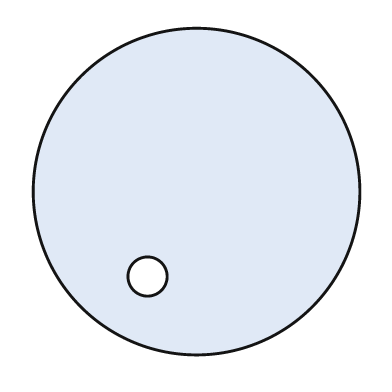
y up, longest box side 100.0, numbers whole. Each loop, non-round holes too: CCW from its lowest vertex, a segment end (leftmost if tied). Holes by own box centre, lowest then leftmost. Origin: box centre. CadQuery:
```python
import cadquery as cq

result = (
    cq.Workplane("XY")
    .moveTo(0.0, 0.0)
    .circle(50.0)
    .moveTo(-15.0, -26.0)
    .circle(6.0)
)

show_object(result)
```